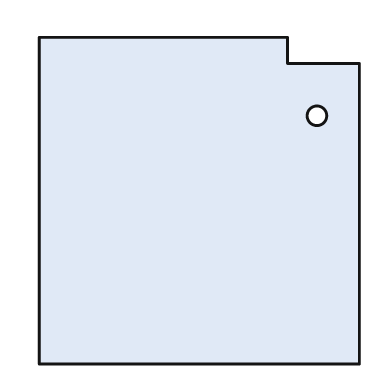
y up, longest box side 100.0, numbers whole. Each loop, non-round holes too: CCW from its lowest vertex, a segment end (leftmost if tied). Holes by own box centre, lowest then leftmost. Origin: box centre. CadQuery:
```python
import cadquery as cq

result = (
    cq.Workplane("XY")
    .moveTo(-49.0, -50.0)
    .lineTo(49.0, -50.0)
    .lineTo(49.0, 42.0)
    .lineTo(27.0, 42.0)
    .lineTo(27.0, 50.0)
    .lineTo(-49.0, 50.0)
    .close()
    .moveTo(36.0, 26.0)
    .circle(3.0)
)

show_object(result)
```